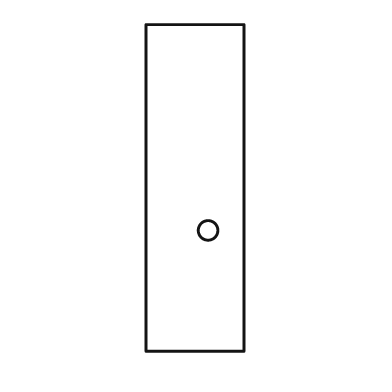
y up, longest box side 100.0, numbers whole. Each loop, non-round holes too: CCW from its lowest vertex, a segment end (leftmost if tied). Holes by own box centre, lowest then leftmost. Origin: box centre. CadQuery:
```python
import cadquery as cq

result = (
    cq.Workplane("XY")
    .moveTo(-15.0, -50.0)
    .lineTo(15.0, -50.0)
    .lineTo(15.0, 50.0)
    .lineTo(-15.0, 50.0)
    .close()
    .moveTo(4.0, -13.0)
    .circle(3.0)
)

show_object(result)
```